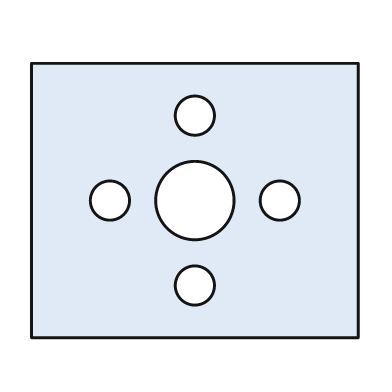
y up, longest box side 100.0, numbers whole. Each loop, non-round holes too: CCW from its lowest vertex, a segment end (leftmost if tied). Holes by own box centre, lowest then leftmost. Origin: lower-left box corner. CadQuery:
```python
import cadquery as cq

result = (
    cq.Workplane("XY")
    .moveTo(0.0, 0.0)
    .lineTo(100.0, 0.0)
    .lineTo(100.0, 84.0)
    .lineTo(0.0, 84.0)
    .close()
    .moveTo(50.0, 16.0)
    .circle(6.0)
    .moveTo(24.0, 42.0)
    .circle(6.0)
    .moveTo(50.0, 42.0)
    .circle(12.0)
    .moveTo(76.0, 42.0)
    .circle(6.0)
    .moveTo(50.0, 68.0)
    .circle(6.0)
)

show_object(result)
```